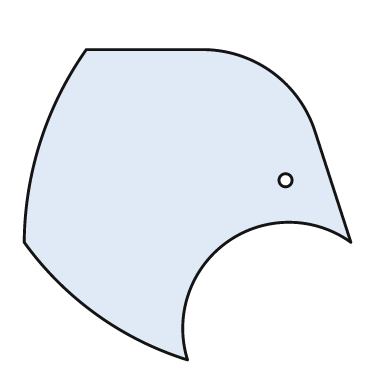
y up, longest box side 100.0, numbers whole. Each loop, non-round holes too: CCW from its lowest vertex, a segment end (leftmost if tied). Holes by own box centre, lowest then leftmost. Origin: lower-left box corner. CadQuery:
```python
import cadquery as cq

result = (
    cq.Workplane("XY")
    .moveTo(50.0, 0.0)
    .threePointArc((62.0, 36.0), (100.0, 36.0))
    .lineTo(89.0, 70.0)
    .threePointArc((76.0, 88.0), (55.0, 95.0))
    .lineTo(19.0, 95.0)
    .threePointArc((5.0, 67.0), (0.0, 36.0))
    .threePointArc((22.0, 14.0), (50.0, 0.0))
    .close()
    .moveTo(80.0, 55.0)
    .circle(2.0)
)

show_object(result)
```